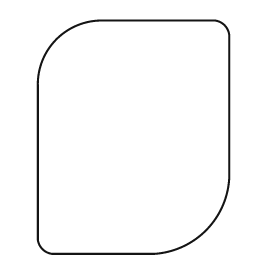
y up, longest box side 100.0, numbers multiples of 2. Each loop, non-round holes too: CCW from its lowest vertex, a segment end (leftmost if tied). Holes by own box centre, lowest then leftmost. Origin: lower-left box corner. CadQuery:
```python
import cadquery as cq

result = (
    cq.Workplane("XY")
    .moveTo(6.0, 0.0)
    .lineTo(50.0, 0.0)
    .threePointArc((72.0, 10.0), (82.0, 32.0))
    .lineTo(82.0, 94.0)
    .threePointArc((80.0, 98.0), (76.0, 100.0))
    .lineTo(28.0, 100.0)
    .threePointArc((8.0, 92.0), (0.0, 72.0))
    .lineTo(0.0, 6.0)
    .threePointArc((2.0, 2.0), (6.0, 0.0))
    .close()
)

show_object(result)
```